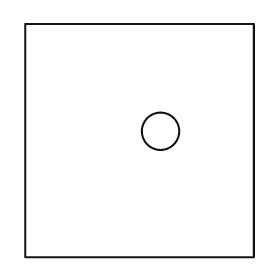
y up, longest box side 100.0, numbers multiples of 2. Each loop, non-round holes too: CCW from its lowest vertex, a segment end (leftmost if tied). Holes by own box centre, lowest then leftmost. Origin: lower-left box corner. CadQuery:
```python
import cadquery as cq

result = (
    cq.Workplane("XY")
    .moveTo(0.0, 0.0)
    .lineTo(98.0, 0.0)
    .lineTo(98.0, 100.0)
    .lineTo(0.0, 100.0)
    .close()
    .moveTo(58.0, 54.0)
    .circle(8.0)
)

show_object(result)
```